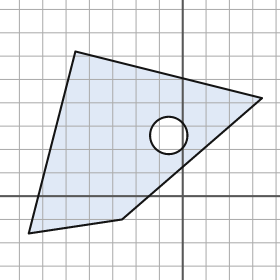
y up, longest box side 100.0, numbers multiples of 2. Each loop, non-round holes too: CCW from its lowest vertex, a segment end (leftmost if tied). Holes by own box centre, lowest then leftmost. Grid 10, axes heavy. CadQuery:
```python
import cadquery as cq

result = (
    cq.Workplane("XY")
    .moveTo(-66.0, -16.0)
    .lineTo(-26.0, -10.0)
    .lineTo(34.0, 42.0)
    .lineTo(-46.0, 62.0)
    .close()
    .moveTo(-6.0, 26.0)
    .circle(8.0)
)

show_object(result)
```